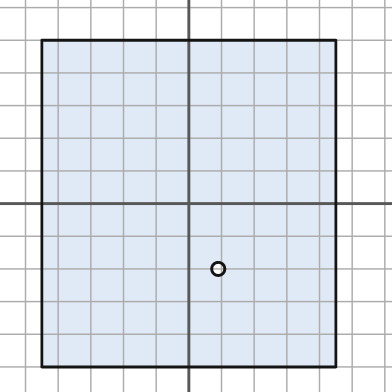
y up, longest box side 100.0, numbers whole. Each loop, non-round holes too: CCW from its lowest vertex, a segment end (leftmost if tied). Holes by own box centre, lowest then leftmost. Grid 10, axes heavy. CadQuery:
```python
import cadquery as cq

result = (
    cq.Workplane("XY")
    .moveTo(-45.0, -50.0)
    .lineTo(45.0, -50.0)
    .lineTo(45.0, 50.0)
    .lineTo(-45.0, 50.0)
    .close()
    .moveTo(9.0, -20.0)
    .circle(2.0)
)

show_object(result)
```